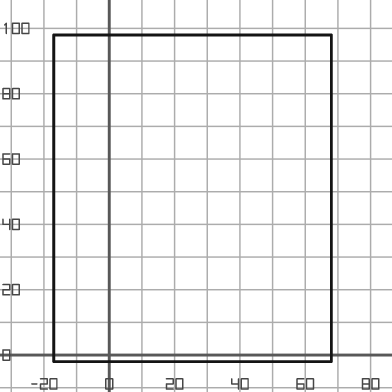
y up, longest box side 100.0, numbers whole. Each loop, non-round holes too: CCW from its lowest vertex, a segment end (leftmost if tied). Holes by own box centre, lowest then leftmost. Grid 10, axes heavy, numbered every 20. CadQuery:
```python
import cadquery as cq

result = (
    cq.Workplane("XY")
    .moveTo(-17.0, -2.0)
    .lineTo(68.0, -2.0)
    .lineTo(68.0, 98.0)
    .lineTo(-17.0, 98.0)
    .close()
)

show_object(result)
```